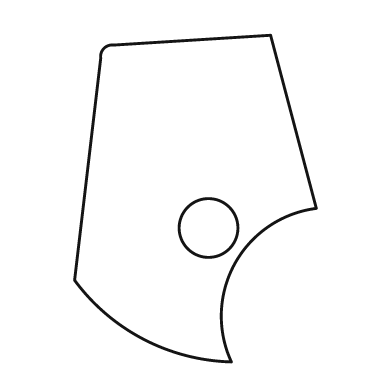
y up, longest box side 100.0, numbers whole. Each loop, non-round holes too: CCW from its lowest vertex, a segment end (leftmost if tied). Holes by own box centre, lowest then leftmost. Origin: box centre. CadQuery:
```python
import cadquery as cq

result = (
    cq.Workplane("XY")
    .moveTo(11.0, -50.0)
    .threePointArc((12.0, -20.0), (37.0, -3.0))
    .lineTo(23.0, 50.0)
    .lineTo(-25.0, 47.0)
    .threePointArc((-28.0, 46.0), (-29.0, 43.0))
    .lineTo(-37.0, -25.0)
    .threePointArc((-16.0, -43.0), (11.0, -50.0))
    .close()
    .moveTo(4.0, -9.0)
    .circle(9.0)
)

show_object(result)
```